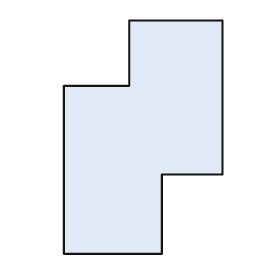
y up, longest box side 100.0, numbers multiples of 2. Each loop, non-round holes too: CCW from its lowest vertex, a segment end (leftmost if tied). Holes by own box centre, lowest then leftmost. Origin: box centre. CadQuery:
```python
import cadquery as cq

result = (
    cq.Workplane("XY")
    .moveTo(-34.0, -50.0)
    .lineTo(8.0, -50.0)
    .lineTo(8.0, -16.0)
    .lineTo(34.0, -16.0)
    .lineTo(34.0, 50.0)
    .lineTo(-6.0, 50.0)
    .lineTo(-6.0, 22.0)
    .lineTo(-34.0, 22.0)
    .close()
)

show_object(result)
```